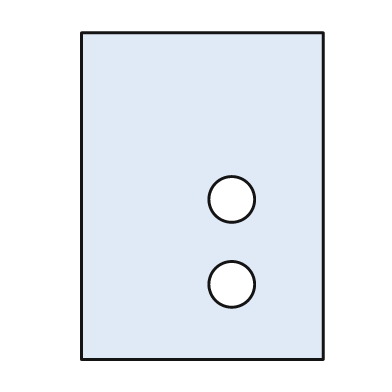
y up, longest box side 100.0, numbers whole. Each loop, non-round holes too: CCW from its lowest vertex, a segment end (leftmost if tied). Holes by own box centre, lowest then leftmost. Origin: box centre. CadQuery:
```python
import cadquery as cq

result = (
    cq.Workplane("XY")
    .moveTo(-37.0, -50.0)
    .lineTo(37.0, -50.0)
    .lineTo(37.0, 50.0)
    .lineTo(-37.0, 50.0)
    .close()
    .moveTo(9.0, -27.0)
    .circle(7.0)
    .moveTo(9.0, -1.0)
    .circle(7.0)
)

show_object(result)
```